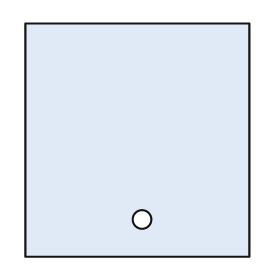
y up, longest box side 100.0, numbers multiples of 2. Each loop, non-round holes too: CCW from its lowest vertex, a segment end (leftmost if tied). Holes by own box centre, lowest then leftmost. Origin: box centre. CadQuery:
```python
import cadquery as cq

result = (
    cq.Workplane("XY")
    .moveTo(-48.0, -50.0)
    .lineTo(48.0, -50.0)
    .lineTo(48.0, 50.0)
    .lineTo(-48.0, 50.0)
    .close()
    .moveTo(2.0, -34.0)
    .circle(4.0)
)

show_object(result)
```